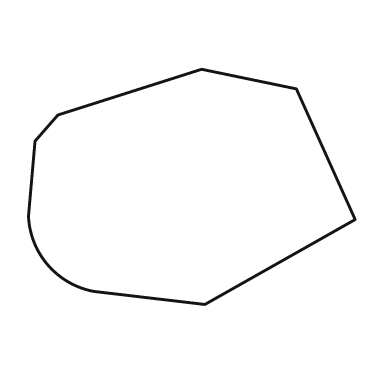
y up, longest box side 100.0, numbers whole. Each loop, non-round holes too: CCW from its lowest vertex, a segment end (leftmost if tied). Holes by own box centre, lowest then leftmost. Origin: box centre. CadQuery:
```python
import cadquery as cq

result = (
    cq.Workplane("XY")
    .moveTo(4.0, -36.0)
    .lineTo(50.0, -10.0)
    .lineTo(32.0, 30.0)
    .lineTo(3.0, 36.0)
    .lineTo(-41.0, 22.0)
    .lineTo(-48.0, 14.0)
    .lineTo(-50.0, -9.0)
    .threePointArc((-44.0, -24.0), (-30.0, -32.0))
    .close()
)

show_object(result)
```